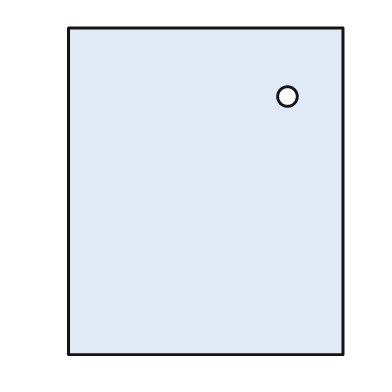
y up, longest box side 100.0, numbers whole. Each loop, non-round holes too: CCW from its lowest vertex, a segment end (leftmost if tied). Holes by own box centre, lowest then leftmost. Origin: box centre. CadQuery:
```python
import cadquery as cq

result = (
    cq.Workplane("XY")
    .moveTo(-42.0, -50.0)
    .lineTo(42.0, -50.0)
    .lineTo(42.0, 50.0)
    .lineTo(-42.0, 50.0)
    .close()
    .moveTo(25.0, 29.0)
    .circle(3.0)
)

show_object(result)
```